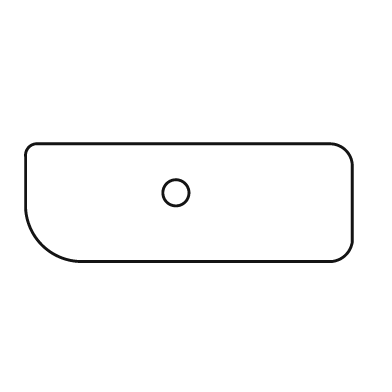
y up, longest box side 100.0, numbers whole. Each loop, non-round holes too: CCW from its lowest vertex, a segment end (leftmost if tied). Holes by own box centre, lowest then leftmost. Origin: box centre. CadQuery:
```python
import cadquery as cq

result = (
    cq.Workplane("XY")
    .moveTo(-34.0, -18.0)
    .lineTo(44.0, -18.0)
    .threePointArc((48.0, -16.0), (50.0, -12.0))
    .lineTo(50.0, 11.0)
    .threePointArc((48.0, 16.0), (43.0, 18.0))
    .lineTo(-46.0, 18.0)
    .threePointArc((-49.0, 17.0), (-50.0, 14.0))
    .lineTo(-50.0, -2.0)
    .threePointArc((-45.0, -13.0), (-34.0, -18.0))
    .close()
    .moveTo(-4.0, 3.0)
    .circle(4.0)
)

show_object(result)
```